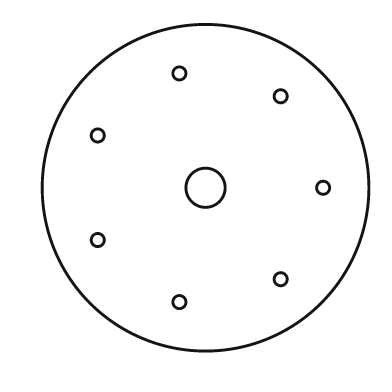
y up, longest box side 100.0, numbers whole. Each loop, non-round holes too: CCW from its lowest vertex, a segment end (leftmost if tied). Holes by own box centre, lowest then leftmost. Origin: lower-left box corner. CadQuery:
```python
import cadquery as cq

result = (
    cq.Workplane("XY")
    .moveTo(50.0, 50.0)
    .circle(50.0)
    .moveTo(42.0, 15.0)
    .circle(2.0)
    .moveTo(73.0, 22.0)
    .circle(2.0)
    .moveTo(17.0, 34.0)
    .circle(2.0)
    .moveTo(50.0, 50.0)
    .circle(6.0)
    .moveTo(86.0, 50.0)
    .circle(2.0)
    .moveTo(17.0, 66.0)
    .circle(2.0)
    .moveTo(73.0, 78.0)
    .circle(2.0)
    .moveTo(42.0, 85.0)
    .circle(2.0)
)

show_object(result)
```